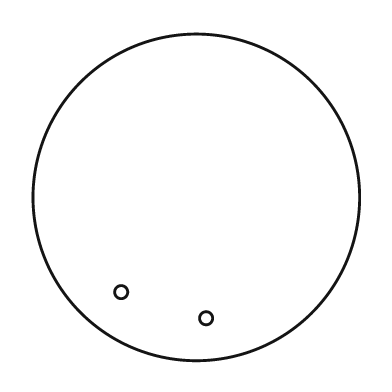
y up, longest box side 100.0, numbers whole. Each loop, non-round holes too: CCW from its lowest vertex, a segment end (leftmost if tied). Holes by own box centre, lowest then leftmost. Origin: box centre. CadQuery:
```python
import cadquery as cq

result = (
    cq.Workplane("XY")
    .moveTo(0.0, 0.0)
    .circle(50.0)
    .moveTo(3.0, -37.0)
    .circle(2.0)
    .moveTo(-23.0, -29.0)
    .circle(2.0)
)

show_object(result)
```